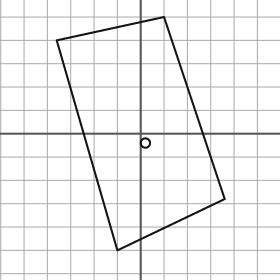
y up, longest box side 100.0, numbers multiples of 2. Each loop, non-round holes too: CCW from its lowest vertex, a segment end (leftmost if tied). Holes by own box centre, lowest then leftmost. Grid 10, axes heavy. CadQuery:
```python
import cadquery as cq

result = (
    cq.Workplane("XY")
    .moveTo(-10.0, -50.0)
    .lineTo(36.0, -28.0)
    .lineTo(10.0, 50.0)
    .lineTo(-36.0, 40.0)
    .close()
    .moveTo(2.0, -4.0)
    .circle(2.0)
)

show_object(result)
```